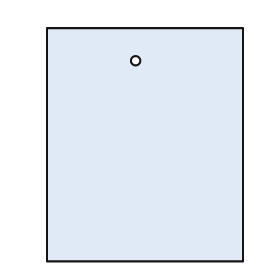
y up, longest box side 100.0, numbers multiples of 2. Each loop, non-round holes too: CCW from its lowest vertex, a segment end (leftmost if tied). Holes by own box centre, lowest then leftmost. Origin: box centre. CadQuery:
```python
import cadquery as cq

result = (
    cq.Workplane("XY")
    .moveTo(-42.0, -50.0)
    .lineTo(42.0, -50.0)
    .lineTo(42.0, 50.0)
    .lineTo(-42.0, 50.0)
    .close()
    .moveTo(-4.0, 36.0)
    .circle(2.0)
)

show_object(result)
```